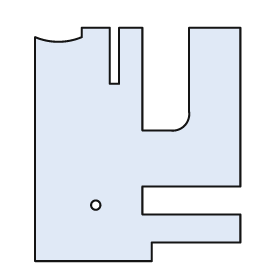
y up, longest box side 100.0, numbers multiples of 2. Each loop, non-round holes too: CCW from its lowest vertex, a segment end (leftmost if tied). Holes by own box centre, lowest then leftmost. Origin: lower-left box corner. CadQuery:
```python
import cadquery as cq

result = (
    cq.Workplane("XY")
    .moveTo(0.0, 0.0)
    .lineTo(50.0, 0.0)
    .lineTo(50.0, 8.0)
    .lineTo(88.0, 8.0)
    .lineTo(88.0, 20.0)
    .lineTo(46.0, 20.0)
    .lineTo(46.0, 32.0)
    .lineTo(88.0, 32.0)
    .lineTo(88.0, 100.0)
    .lineTo(66.0, 100.0)
    .lineTo(66.0, 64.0)
    .threePointArc((64.0, 58.0), (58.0, 56.0))
    .lineTo(46.0, 56.0)
    .lineTo(46.0, 100.0)
    .lineTo(36.0, 100.0)
    .lineTo(36.0, 76.0)
    .lineTo(32.0, 76.0)
    .lineTo(32.0, 100.0)
    .lineTo(20.0, 100.0)
    .lineTo(20.0, 96.0)
    .threePointArc((10.0, 94.0), (0.0, 96.0))
    .close()
    .moveTo(26.0, 24.0)
    .circle(2.0)
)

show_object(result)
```